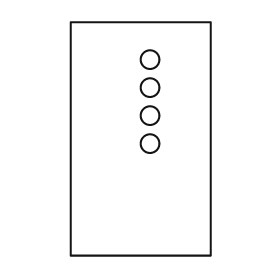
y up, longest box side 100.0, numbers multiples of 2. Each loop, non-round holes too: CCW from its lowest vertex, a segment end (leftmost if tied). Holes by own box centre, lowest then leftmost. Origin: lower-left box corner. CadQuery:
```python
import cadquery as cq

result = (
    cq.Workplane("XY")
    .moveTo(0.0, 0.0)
    .lineTo(60.0, 0.0)
    .lineTo(60.0, 100.0)
    .lineTo(0.0, 100.0)
    .close()
    .moveTo(34.0, 48.0)
    .circle(4.0)
    .moveTo(34.0, 60.0)
    .circle(4.0)
    .moveTo(34.0, 72.0)
    .circle(4.0)
    .moveTo(34.0, 84.0)
    .circle(4.0)
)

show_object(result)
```